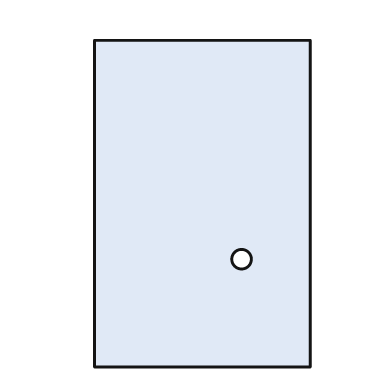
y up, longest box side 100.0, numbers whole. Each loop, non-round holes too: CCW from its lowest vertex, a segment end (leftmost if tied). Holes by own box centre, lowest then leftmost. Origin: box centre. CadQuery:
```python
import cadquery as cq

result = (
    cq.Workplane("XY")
    .moveTo(-33.0, -50.0)
    .lineTo(33.0, -50.0)
    .lineTo(33.0, 50.0)
    .lineTo(-33.0, 50.0)
    .close()
    .moveTo(12.0, -17.0)
    .circle(3.0)
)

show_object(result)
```